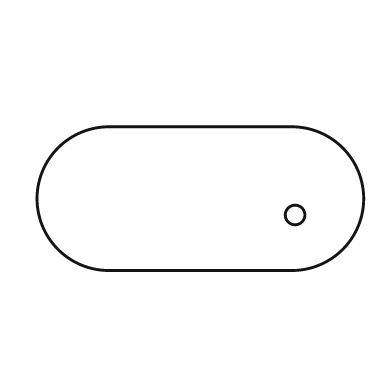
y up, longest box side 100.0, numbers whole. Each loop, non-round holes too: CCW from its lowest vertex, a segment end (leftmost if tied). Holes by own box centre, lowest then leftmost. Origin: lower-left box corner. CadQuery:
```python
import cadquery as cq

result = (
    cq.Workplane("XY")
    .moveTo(22.0, 0.0)
    .lineTo(78.0, 0.0)
    .threePointArc((100.0, 22.0), (78.0, 44.0))
    .lineTo(22.0, 44.0)
    .threePointArc((0.0, 22.0), (22.0, 0.0))
    .close()
    .moveTo(79.0, 17.0)
    .circle(3.0)
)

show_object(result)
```